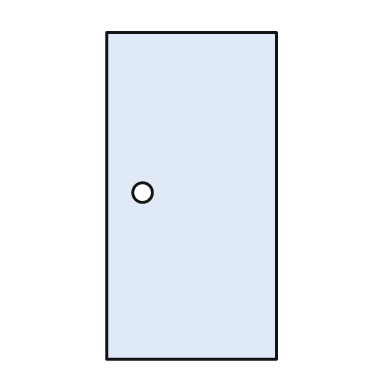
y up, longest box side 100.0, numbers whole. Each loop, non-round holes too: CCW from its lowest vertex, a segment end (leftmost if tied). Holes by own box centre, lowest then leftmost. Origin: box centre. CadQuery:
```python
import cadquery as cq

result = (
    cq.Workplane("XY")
    .moveTo(-26.0, -50.0)
    .lineTo(26.0, -50.0)
    .lineTo(26.0, 50.0)
    .lineTo(-26.0, 50.0)
    .close()
    .moveTo(-15.0, 1.0)
    .circle(3.0)
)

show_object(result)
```